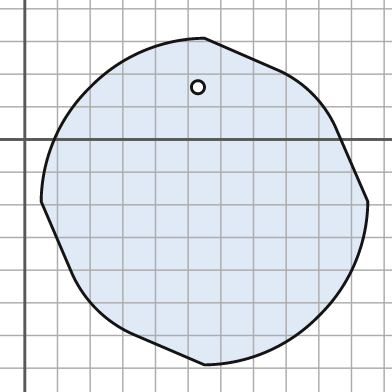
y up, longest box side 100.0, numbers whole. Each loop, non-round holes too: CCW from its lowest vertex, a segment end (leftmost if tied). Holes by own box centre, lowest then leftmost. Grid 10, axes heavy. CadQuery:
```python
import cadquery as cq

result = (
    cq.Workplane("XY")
    .moveTo(55.0, -69.0)
    .threePointArc((74.0, -65.0), (90.0, -54.0))
    .threePointArc((101.0, -38.0), (105.0, -19.0))
    .lineTo(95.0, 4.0)
    .threePointArc((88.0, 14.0), (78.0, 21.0))
    .lineTo(55.0, 31.0)
    .threePointArc((36.0, 27.0), (20.0, 16.0))
    .threePointArc((9.0, 0.0), (5.0, -19.0))
    .lineTo(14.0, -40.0)
    .threePointArc((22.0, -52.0), (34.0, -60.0))
    .close()
    .moveTo(53.0, 16.0)
    .circle(2.0)
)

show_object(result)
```